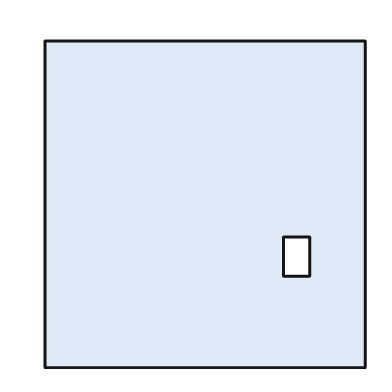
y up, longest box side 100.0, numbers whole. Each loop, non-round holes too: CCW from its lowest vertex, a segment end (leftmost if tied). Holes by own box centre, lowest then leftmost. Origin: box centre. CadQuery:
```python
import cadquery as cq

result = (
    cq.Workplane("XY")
    .moveTo(-49.0, -50.0)
    .lineTo(49.0, -50.0)
    .lineTo(49.0, 50.0)
    .lineTo(-49.0, 50.0)
    .close()
    .moveTo(24.0, -22.0)
    .lineTo(32.0, -22.0)
    .lineTo(32.0, -10.0)
    .lineTo(24.0, -10.0)
    .close()
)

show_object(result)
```